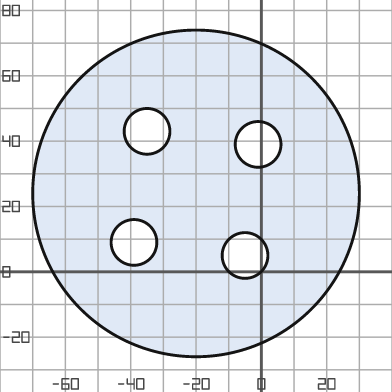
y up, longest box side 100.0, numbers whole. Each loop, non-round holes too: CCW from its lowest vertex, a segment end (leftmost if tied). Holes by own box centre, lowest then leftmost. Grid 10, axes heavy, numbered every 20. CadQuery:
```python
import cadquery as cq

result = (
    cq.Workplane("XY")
    .moveTo(-20.0, 24.0)
    .circle(50.0)
    .moveTo(-5.0, 5.0)
    .circle(7.0)
    .moveTo(-39.0, 9.0)
    .circle(7.0)
    .moveTo(-1.0, 39.0)
    .circle(7.0)
    .moveTo(-35.0, 43.0)
    .circle(7.0)
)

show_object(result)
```